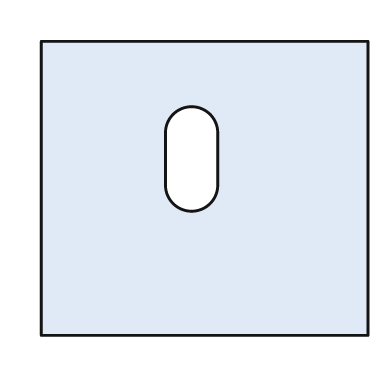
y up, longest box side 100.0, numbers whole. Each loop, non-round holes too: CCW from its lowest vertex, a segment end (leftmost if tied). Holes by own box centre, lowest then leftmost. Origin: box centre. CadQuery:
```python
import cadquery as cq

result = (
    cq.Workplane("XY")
    .moveTo(-50.0, -45.0)
    .lineTo(50.0, -45.0)
    .lineTo(50.0, 45.0)
    .lineTo(-50.0, 45.0)
    .close()
    .moveTo(-12.0, 1.0)
    .threePointArc((-4.0, -7.0), (4.0, 1.0))
    .lineTo(4.0, 17.0)
    .threePointArc((-4.0, 25.0), (-12.0, 17.0))
    .close()
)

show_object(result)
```